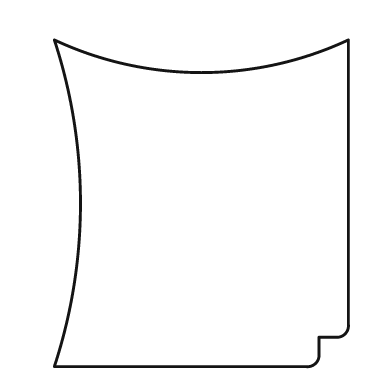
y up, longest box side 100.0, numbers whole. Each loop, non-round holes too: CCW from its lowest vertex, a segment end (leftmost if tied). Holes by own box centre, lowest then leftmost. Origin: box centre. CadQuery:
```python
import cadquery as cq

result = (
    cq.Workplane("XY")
    .moveTo(-45.0, -50.0)
    .lineTo(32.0, -50.0)
    .threePointArc((35.0, -49.0), (36.0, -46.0))
    .lineTo(36.0, -41.0)
    .lineTo(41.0, -41.0)
    .threePointArc((44.0, -40.0), (45.0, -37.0))
    .lineTo(45.0, 50.0)
    .threePointArc((0.0, 40.0), (-45.0, 50.0))
    .threePointArc((-37.0, 0.0), (-45.0, -50.0))
    .close()
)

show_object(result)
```